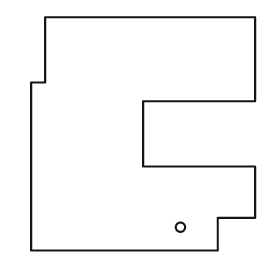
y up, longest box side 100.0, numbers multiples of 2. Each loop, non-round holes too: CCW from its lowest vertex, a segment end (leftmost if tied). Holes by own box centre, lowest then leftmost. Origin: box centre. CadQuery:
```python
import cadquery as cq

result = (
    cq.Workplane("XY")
    .moveTo(-48.0, -50.0)
    .lineTo(32.0, -50.0)
    .lineTo(32.0, -36.0)
    .lineTo(48.0, -36.0)
    .lineTo(48.0, -14.0)
    .lineTo(0.0, -14.0)
    .lineTo(0.0, 14.0)
    .lineTo(48.0, 14.0)
    .lineTo(48.0, 50.0)
    .lineTo(-42.0, 50.0)
    .lineTo(-42.0, 22.0)
    .lineTo(-48.0, 22.0)
    .close()
    .moveTo(16.0, -40.0)
    .circle(2.0)
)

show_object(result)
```